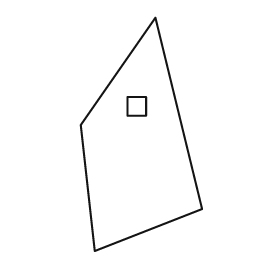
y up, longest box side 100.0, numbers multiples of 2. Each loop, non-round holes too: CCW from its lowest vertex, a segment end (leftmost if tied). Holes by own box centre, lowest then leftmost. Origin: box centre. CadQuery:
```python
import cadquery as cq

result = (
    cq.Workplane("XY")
    .moveTo(-20.0, -50.0)
    .lineTo(26.0, -32.0)
    .lineTo(6.0, 50.0)
    .lineTo(-26.0, 4.0)
    .close()
    .moveTo(-6.0, 8.0)
    .lineTo(2.0, 8.0)
    .lineTo(2.0, 16.0)
    .lineTo(-6.0, 16.0)
    .close()
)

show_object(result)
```